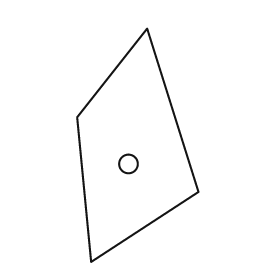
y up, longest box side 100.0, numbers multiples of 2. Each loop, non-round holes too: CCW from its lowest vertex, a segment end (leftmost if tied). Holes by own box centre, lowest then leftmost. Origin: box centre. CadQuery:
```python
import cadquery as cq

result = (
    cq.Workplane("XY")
    .moveTo(-20.0, -50.0)
    .lineTo(26.0, -20.0)
    .lineTo(4.0, 50.0)
    .lineTo(-26.0, 12.0)
    .close()
    .moveTo(-4.0, -8.0)
    .circle(4.0)
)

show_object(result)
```